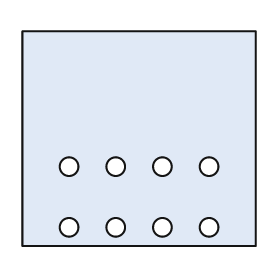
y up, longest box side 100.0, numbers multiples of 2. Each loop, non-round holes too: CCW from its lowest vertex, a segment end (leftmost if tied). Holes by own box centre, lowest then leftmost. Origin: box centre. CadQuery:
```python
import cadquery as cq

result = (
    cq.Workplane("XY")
    .moveTo(-50.0, -46.0)
    .lineTo(50.0, -46.0)
    .lineTo(50.0, 46.0)
    .lineTo(-50.0, 46.0)
    .close()
    .moveTo(-30.0, -38.0)
    .circle(4.0)
    .moveTo(-10.0, -38.0)
    .circle(4.0)
    .moveTo(10.0, -38.0)
    .circle(4.0)
    .moveTo(30.0, -38.0)
    .circle(4.0)
    .moveTo(-30.0, -12.0)
    .circle(4.0)
    .moveTo(-10.0, -12.0)
    .circle(4.0)
    .moveTo(10.0, -12.0)
    .circle(4.0)
    .moveTo(30.0, -12.0)
    .circle(4.0)
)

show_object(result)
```